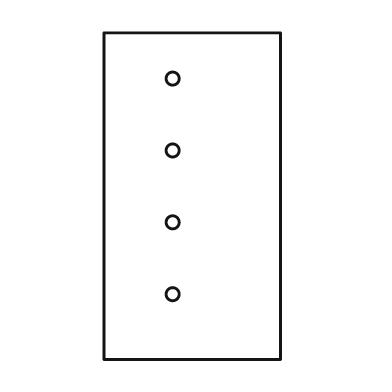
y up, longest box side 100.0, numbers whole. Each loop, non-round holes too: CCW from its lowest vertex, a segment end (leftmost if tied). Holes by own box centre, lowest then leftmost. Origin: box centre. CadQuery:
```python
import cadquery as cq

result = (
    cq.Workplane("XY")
    .moveTo(-27.0, -50.0)
    .lineTo(27.0, -50.0)
    .lineTo(27.0, 50.0)
    .lineTo(-27.0, 50.0)
    .close()
    .moveTo(-6.0, -30.0)
    .circle(2.0)
    .moveTo(-6.0, -8.0)
    .circle(2.0)
    .moveTo(-6.0, 14.0)
    .circle(2.0)
    .moveTo(-6.0, 36.0)
    .circle(2.0)
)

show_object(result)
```